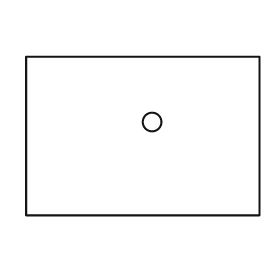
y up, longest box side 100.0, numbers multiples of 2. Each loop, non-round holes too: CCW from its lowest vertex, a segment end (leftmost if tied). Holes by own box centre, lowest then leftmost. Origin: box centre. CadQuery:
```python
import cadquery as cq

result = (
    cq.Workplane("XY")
    .moveTo(-50.0, -34.0)
    .lineTo(50.0, -34.0)
    .lineTo(50.0, 34.0)
    .lineTo(-50.0, 34.0)
    .close()
    .moveTo(4.0, 6.0)
    .circle(4.0)
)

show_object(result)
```